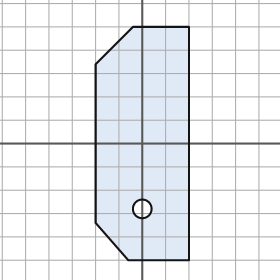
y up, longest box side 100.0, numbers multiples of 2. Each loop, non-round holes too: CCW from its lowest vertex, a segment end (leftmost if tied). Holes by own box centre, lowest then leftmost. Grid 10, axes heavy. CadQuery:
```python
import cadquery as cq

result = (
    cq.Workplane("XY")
    .moveTo(-6.0, -50.0)
    .lineTo(20.0, -50.0)
    .lineTo(20.0, 50.0)
    .lineTo(-4.0, 50.0)
    .lineTo(-20.0, 34.0)
    .lineTo(-20.0, -34.0)
    .close()
    .moveTo(0.0, -28.0)
    .circle(4.0)
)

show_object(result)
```